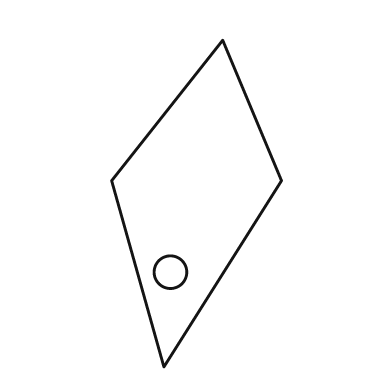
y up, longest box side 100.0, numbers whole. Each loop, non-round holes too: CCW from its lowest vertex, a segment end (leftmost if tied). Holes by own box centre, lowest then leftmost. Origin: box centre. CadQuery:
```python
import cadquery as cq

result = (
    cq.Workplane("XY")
    .moveTo(-10.0, -50.0)
    .lineTo(26.0, 7.0)
    .lineTo(8.0, 50.0)
    .lineTo(-26.0, 7.0)
    .close()
    .moveTo(-8.0, -21.0)
    .circle(5.0)
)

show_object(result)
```